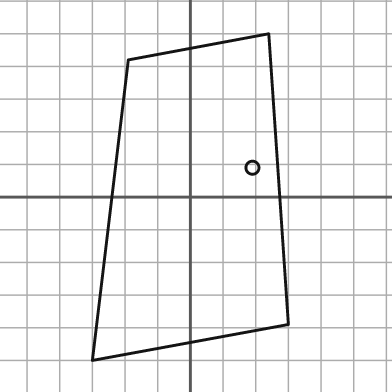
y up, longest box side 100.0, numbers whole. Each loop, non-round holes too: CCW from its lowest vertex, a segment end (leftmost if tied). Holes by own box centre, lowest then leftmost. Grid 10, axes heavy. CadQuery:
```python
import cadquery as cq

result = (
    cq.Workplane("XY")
    .moveTo(-30.0, -50.0)
    .lineTo(30.0, -39.0)
    .lineTo(24.0, 50.0)
    .lineTo(-19.0, 42.0)
    .close()
    .moveTo(19.0, 9.0)
    .circle(2.0)
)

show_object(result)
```